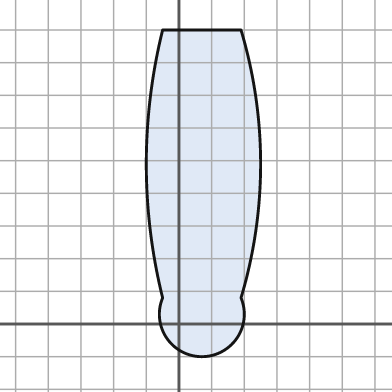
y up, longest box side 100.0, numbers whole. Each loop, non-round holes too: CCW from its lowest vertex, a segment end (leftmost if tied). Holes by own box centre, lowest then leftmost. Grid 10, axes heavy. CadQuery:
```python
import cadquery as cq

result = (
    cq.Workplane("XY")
    .moveTo(-5.0, 8.0)
    .threePointArc((7.0, -10.0), (19.0, 8.0))
    .threePointArc((25.0, 49.0), (19.0, 90.0))
    .lineTo(-5.0, 90.0)
    .threePointArc((-10.0, 49.0), (-5.0, 8.0))
    .close()
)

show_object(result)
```